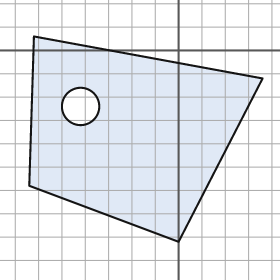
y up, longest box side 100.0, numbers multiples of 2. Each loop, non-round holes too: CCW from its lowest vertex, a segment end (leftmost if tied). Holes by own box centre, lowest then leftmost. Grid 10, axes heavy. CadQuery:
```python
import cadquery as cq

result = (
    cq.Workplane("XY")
    .moveTo(0.0, -82.0)
    .lineTo(36.0, -12.0)
    .lineTo(-62.0, 6.0)
    .lineTo(-64.0, -58.0)
    .close()
    .moveTo(-42.0, -24.0)
    .circle(8.0)
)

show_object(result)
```